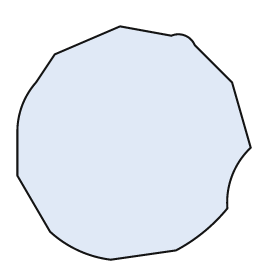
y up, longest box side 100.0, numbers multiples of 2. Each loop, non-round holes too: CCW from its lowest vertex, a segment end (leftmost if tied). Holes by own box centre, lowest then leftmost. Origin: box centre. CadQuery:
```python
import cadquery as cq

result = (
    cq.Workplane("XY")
    .moveTo(-10.0, -50.0)
    .lineTo(18.0, -46.0)
    .threePointArc((30.0, -38.0), (40.0, -28.0))
    .threePointArc((42.0, -14.0), (50.0, -2.0))
    .lineTo(42.0, 26.0)
    .lineTo(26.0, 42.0)
    .threePointArc((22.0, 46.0), (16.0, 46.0))
    .lineTo(-6.0, 50.0)
    .lineTo(-34.0, 38.0)
    .lineTo(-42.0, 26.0)
    .threePointArc((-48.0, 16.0), (-50.0, 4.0))
    .lineTo(-50.0, -14.0)
    .lineTo(-36.0, -38.0)
    .threePointArc((-24.0, -46.0), (-10.0, -50.0))
    .close()
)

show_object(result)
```